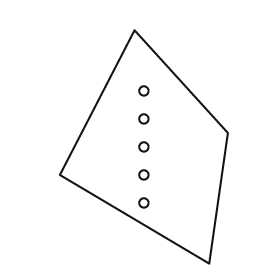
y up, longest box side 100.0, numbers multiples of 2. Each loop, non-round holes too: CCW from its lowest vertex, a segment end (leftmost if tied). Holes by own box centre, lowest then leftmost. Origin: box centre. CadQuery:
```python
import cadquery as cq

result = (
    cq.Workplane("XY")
    .moveTo(28.0, -50.0)
    .lineTo(36.0, 6.0)
    .lineTo(-4.0, 50.0)
    .lineTo(-36.0, -12.0)
    .close()
    .moveTo(0.0, -24.0)
    .circle(2.0)
    .moveTo(0.0, -12.0)
    .circle(2.0)
    .moveTo(0.0, 0.0)
    .circle(2.0)
    .moveTo(0.0, 12.0)
    .circle(2.0)
    .moveTo(0.0, 24.0)
    .circle(2.0)
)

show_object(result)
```